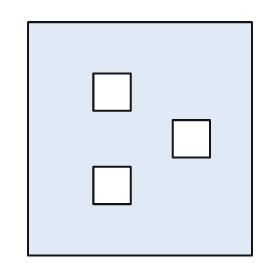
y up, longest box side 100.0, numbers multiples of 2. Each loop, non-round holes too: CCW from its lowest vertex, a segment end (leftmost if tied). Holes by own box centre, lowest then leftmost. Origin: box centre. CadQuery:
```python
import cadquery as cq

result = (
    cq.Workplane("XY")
    .moveTo(-48.0, -50.0)
    .lineTo(48.0, -50.0)
    .lineTo(48.0, 50.0)
    .lineTo(-48.0, 50.0)
    .close()
    .moveTo(-20.0, -28.0)
    .lineTo(-4.0, -28.0)
    .lineTo(-4.0, -12.0)
    .lineTo(-20.0, -12.0)
    .close()
    .moveTo(14.0, -8.0)
    .lineTo(30.0, -8.0)
    .lineTo(30.0, 8.0)
    .lineTo(14.0, 8.0)
    .close()
    .moveTo(-20.0, 12.0)
    .lineTo(-4.0, 12.0)
    .lineTo(-4.0, 28.0)
    .lineTo(-20.0, 28.0)
    .close()
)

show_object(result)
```